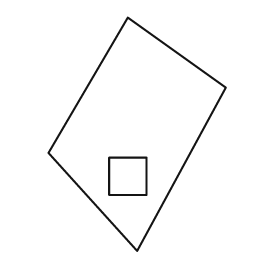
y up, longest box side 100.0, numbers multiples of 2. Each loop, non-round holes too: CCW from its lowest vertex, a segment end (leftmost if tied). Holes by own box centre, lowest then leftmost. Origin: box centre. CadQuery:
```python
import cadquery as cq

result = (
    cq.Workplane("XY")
    .moveTo(0.0, -50.0)
    .lineTo(38.0, 20.0)
    .lineTo(-4.0, 50.0)
    .lineTo(-38.0, -8.0)
    .close()
    .moveTo(-12.0, -26.0)
    .lineTo(4.0, -26.0)
    .lineTo(4.0, -10.0)
    .lineTo(-12.0, -10.0)
    .close()
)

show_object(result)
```